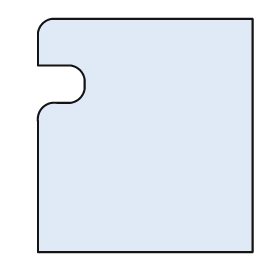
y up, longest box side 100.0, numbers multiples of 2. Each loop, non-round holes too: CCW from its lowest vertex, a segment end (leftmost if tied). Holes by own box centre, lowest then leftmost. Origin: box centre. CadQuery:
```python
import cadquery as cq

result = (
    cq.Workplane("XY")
    .moveTo(-46.0, -50.0)
    .lineTo(46.0, -50.0)
    .lineTo(46.0, 50.0)
    .lineTo(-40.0, 50.0)
    .threePointArc((-44.0, 48.0), (-46.0, 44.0))
    .lineTo(-46.0, 30.0)
    .lineTo(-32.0, 30.0)
    .threePointArc((-28.0, 28.0), (-26.0, 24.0))
    .lineTo(-26.0, 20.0)
    .threePointArc((-28.0, 16.0), (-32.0, 14.0))
    .lineTo(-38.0, 14.0)
    .threePointArc((-44.0, 12.0), (-46.0, 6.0))
    .close()
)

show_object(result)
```